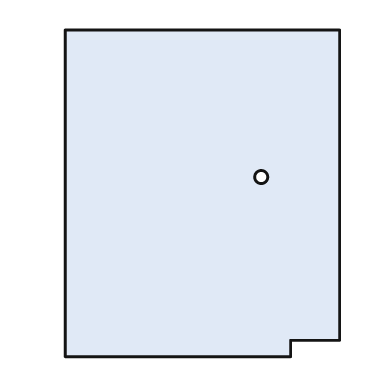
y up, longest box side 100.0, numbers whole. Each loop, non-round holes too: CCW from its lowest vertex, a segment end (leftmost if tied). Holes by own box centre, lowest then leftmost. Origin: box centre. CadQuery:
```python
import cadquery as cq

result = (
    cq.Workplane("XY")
    .moveTo(-42.0, -50.0)
    .lineTo(27.0, -50.0)
    .lineTo(27.0, -45.0)
    .lineTo(42.0, -45.0)
    .lineTo(42.0, 50.0)
    .lineTo(-42.0, 50.0)
    .close()
    .moveTo(18.0, 5.0)
    .circle(2.0)
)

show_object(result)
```